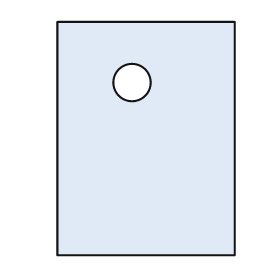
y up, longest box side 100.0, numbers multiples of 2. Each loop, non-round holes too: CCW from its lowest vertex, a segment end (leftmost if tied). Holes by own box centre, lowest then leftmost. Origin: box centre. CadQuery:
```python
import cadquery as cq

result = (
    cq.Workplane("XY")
    .moveTo(-38.0, -50.0)
    .lineTo(38.0, -50.0)
    .lineTo(38.0, 50.0)
    .lineTo(-38.0, 50.0)
    .close()
    .moveTo(-6.0, 24.0)
    .circle(8.0)
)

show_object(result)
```